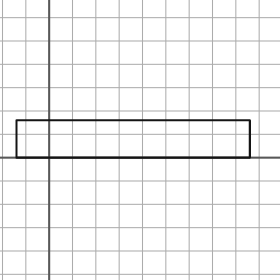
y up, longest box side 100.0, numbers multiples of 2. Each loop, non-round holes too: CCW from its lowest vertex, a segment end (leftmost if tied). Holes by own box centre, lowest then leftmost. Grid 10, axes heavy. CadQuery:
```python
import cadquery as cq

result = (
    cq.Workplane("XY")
    .moveTo(-14.0, 0.0)
    .lineTo(86.0, 0.0)
    .lineTo(86.0, 16.0)
    .lineTo(-14.0, 16.0)
    .close()
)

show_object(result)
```